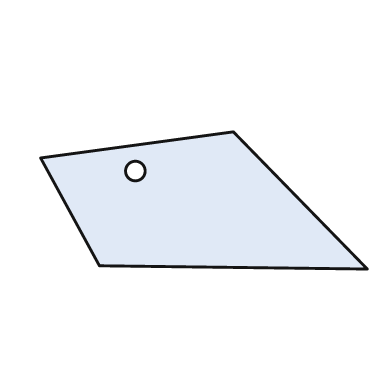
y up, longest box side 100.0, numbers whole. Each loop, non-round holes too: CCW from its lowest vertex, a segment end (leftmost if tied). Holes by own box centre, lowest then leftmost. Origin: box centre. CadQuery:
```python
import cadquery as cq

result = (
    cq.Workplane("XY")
    .moveTo(50.0, -21.0)
    .lineTo(9.0, 21.0)
    .lineTo(-50.0, 13.0)
    .lineTo(-32.0, -20.0)
    .close()
    .moveTo(-21.0, 9.0)
    .circle(3.0)
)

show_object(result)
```